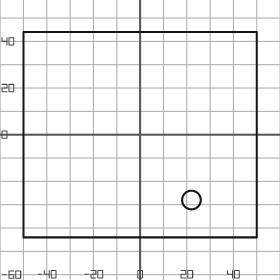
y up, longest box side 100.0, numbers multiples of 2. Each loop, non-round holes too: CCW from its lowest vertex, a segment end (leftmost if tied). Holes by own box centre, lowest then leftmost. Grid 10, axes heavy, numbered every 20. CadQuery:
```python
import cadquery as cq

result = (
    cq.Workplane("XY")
    .moveTo(-50.0, -44.0)
    .lineTo(50.0, -44.0)
    .lineTo(50.0, 44.0)
    .lineTo(-50.0, 44.0)
    .close()
    .moveTo(22.0, -28.0)
    .circle(4.0)
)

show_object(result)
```